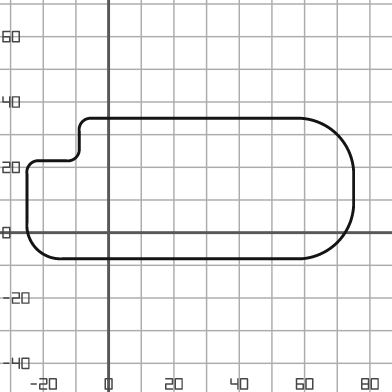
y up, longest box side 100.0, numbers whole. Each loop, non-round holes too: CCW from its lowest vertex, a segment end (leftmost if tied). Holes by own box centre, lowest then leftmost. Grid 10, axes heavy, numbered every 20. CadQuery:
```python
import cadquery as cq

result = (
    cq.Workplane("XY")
    .moveTo(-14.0, -8.0)
    .lineTo(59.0, -8.0)
    .threePointArc((70.0, -3.0), (75.0, 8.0))
    .lineTo(75.0, 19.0)
    .threePointArc((70.0, 30.0), (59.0, 35.0))
    .lineTo(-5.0, 35.0)
    .threePointArc((-8.0, 34.0), (-9.0, 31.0))
    .lineTo(-9.0, 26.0)
    .threePointArc((-10.0, 23.0), (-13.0, 22.0))
    .lineTo(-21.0, 22.0)
    .threePointArc((-24.0, 21.0), (-25.0, 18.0))
    .lineTo(-25.0, 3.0)
    .threePointArc((-22.0, -5.0), (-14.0, -8.0))
    .close()
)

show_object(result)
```